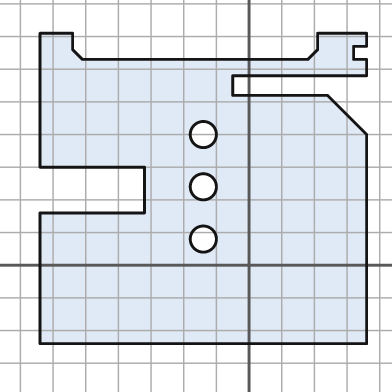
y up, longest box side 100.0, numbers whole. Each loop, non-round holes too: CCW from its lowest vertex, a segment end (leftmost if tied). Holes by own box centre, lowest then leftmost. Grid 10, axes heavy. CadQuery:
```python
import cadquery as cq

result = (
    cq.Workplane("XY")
    .moveTo(-64.0, -24.0)
    .lineTo(36.0, -24.0)
    .lineTo(36.0, 40.0)
    .lineTo(24.0, 52.0)
    .lineTo(-5.0, 52.0)
    .lineTo(-5.0, 58.0)
    .lineTo(36.0, 58.0)
    .lineTo(36.0, 63.0)
    .lineTo(32.0, 63.0)
    .lineTo(32.0, 67.0)
    .lineTo(36.0, 67.0)
    .lineTo(36.0, 71.0)
    .lineTo(21.0, 71.0)
    .lineTo(21.0, 66.0)
    .lineTo(18.0, 63.0)
    .lineTo(-51.0, 63.0)
    .lineTo(-54.0, 66.0)
    .lineTo(-54.0, 71.0)
    .lineTo(-64.0, 71.0)
    .lineTo(-64.0, 30.0)
    .lineTo(-32.0, 30.0)
    .lineTo(-32.0, 16.0)
    .lineTo(-64.0, 16.0)
    .close()
    .moveTo(-14.0, 8.0)
    .circle(4.0)
    .moveTo(-14.0, 24.0)
    .circle(4.0)
    .moveTo(-14.0, 40.0)
    .circle(4.0)
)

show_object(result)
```